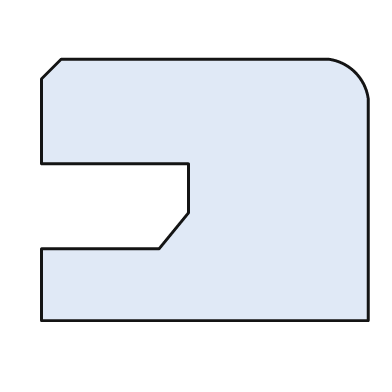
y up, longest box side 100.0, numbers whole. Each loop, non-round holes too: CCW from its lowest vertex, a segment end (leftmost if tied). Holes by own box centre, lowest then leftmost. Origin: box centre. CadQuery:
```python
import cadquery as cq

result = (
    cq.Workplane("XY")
    .moveTo(-50.0, -40.0)
    .lineTo(50.0, -40.0)
    .lineTo(50.0, 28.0)
    .threePointArc((46.0, 36.0), (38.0, 40.0))
    .lineTo(-44.0, 40.0)
    .lineTo(-50.0, 34.0)
    .lineTo(-50.0, 8.0)
    .lineTo(-5.0, 8.0)
    .lineTo(-5.0, -7.0)
    .lineTo(-14.0, -18.0)
    .lineTo(-50.0, -18.0)
    .close()
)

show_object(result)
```